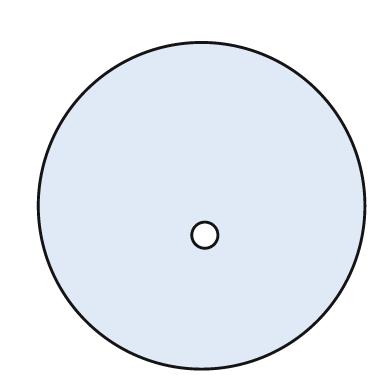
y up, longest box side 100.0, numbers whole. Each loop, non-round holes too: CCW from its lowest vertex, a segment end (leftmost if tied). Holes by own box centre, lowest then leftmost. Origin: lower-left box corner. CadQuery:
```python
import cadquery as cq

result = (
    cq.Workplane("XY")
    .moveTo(50.0, 50.0)
    .circle(50.0)
    .moveTo(51.0, 41.0)
    .circle(4.0)
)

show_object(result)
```